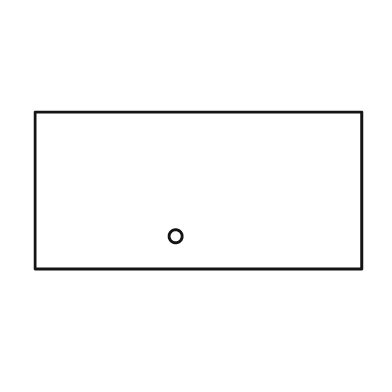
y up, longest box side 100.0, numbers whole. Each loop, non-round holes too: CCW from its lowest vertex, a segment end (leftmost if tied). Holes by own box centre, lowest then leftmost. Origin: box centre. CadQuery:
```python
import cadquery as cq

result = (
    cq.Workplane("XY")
    .moveTo(-50.0, -24.0)
    .lineTo(50.0, -24.0)
    .lineTo(50.0, 24.0)
    .lineTo(-50.0, 24.0)
    .close()
    .moveTo(-7.0, -14.0)
    .circle(2.0)
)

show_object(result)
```